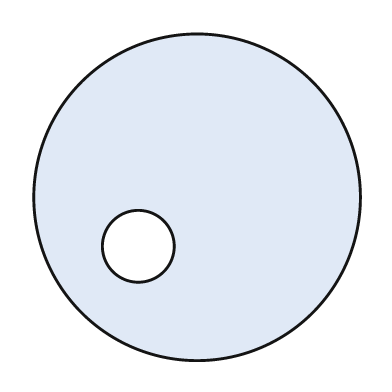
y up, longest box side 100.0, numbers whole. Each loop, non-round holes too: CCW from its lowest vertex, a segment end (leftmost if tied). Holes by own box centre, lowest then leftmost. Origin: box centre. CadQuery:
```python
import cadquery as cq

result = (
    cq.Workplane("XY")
    .moveTo(0.0, 0.0)
    .circle(50.0)
    .moveTo(-18.0, -15.0)
    .circle(11.0)
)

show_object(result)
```